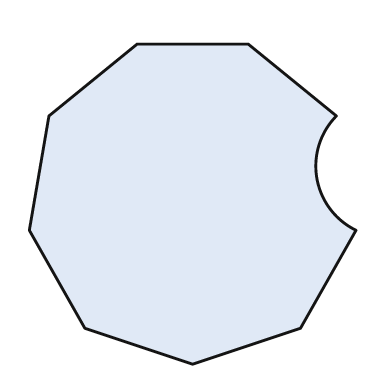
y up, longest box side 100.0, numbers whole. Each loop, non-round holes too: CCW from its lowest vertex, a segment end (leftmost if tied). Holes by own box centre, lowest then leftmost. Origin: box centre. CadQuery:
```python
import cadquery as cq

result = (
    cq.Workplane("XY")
    .moveTo(0.0, -49.0)
    .lineTo(33.0, -38.0)
    .lineTo(50.0, -8.0)
    .threePointArc((38.0, 8.0), (44.0, 27.0))
    .lineTo(17.0, 49.0)
    .lineTo(-17.0, 49.0)
    .lineTo(-44.0, 27.0)
    .lineTo(-50.0, -8.0)
    .lineTo(-33.0, -38.0)
    .close()
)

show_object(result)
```